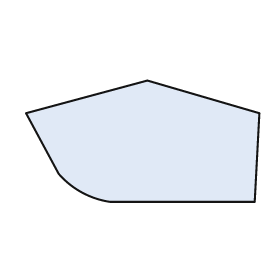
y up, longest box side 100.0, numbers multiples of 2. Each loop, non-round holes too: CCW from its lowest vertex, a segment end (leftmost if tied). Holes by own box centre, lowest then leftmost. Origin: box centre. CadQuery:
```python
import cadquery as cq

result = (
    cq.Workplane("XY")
    .moveTo(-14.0, -26.0)
    .lineTo(48.0, -26.0)
    .lineTo(50.0, 12.0)
    .lineTo(2.0, 26.0)
    .lineTo(-50.0, 12.0)
    .lineTo(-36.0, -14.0)
    .threePointArc((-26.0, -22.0), (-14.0, -26.0))
    .close()
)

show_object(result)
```